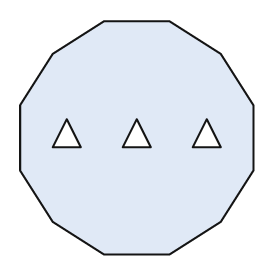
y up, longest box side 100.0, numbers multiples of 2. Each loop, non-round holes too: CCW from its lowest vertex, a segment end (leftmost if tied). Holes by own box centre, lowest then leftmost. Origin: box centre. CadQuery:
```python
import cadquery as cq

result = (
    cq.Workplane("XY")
    .moveTo(-14.0, -50.0)
    .lineTo(14.0, -50.0)
    .lineTo(36.0, -36.0)
    .lineTo(50.0, -14.0)
    .lineTo(50.0, 14.0)
    .lineTo(36.0, 36.0)
    .lineTo(14.0, 50.0)
    .lineTo(-14.0, 50.0)
    .lineTo(-36.0, 36.0)
    .lineTo(-50.0, 14.0)
    .lineTo(-50.0, -14.0)
    .lineTo(-36.0, -36.0)
    .close()
    .moveTo(-36.0, -4.0)
    .lineTo(-24.0, -4.0)
    .lineTo(-30.0, 8.0)
    .close()
    .moveTo(-6.0, -4.0)
    .lineTo(6.0, -4.0)
    .lineTo(0.0, 8.0)
    .close()
    .moveTo(24.0, -4.0)
    .lineTo(36.0, -4.0)
    .lineTo(30.0, 8.0)
    .close()
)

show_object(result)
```